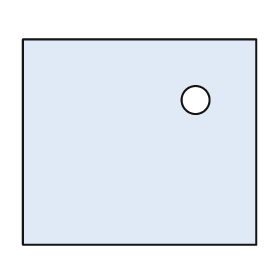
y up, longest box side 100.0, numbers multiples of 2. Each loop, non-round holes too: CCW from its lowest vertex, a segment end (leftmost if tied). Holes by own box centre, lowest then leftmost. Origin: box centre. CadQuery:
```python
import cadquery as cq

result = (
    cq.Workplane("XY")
    .moveTo(-50.0, -44.0)
    .lineTo(50.0, -44.0)
    .lineTo(50.0, 44.0)
    .lineTo(-50.0, 44.0)
    .close()
    .moveTo(24.0, 18.0)
    .circle(6.0)
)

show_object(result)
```